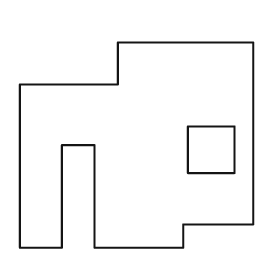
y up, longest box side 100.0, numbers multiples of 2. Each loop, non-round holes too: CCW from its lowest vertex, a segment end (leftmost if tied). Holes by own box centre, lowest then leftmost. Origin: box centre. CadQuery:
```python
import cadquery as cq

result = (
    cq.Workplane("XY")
    .moveTo(-50.0, -44.0)
    .lineTo(-32.0, -44.0)
    .lineTo(-32.0, 0.0)
    .lineTo(-18.0, 0.0)
    .lineTo(-18.0, -44.0)
    .lineTo(20.0, -44.0)
    .lineTo(20.0, -34.0)
    .lineTo(50.0, -34.0)
    .lineTo(50.0, 44.0)
    .lineTo(-8.0, 44.0)
    .lineTo(-8.0, 26.0)
    .lineTo(-50.0, 26.0)
    .close()
    .moveTo(22.0, -12.0)
    .lineTo(42.0, -12.0)
    .lineTo(42.0, 8.0)
    .lineTo(22.0, 8.0)
    .close()
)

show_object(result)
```